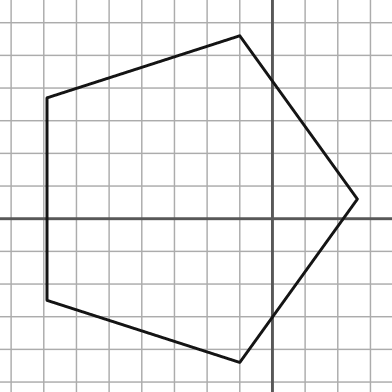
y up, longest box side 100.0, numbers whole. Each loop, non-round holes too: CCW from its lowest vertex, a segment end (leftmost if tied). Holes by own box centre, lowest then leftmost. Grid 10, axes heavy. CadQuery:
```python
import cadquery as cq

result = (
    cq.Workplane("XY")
    .moveTo(-10.0, -44.0)
    .lineTo(26.0, 6.0)
    .lineTo(-10.0, 56.0)
    .lineTo(-69.0, 37.0)
    .lineTo(-69.0, -25.0)
    .close()
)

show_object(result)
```